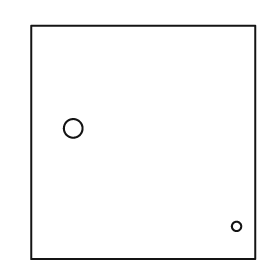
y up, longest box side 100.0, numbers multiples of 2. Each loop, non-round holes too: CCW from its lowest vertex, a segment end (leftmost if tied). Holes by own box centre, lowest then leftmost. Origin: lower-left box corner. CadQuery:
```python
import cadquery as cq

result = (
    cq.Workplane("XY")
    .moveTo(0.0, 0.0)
    .lineTo(96.0, 0.0)
    .lineTo(96.0, 100.0)
    .lineTo(0.0, 100.0)
    .close()
    .moveTo(88.0, 14.0)
    .circle(2.0)
    .moveTo(18.0, 56.0)
    .circle(4.0)
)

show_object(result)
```